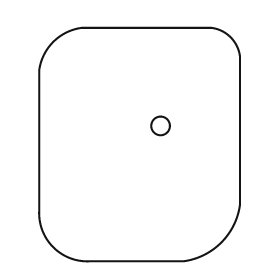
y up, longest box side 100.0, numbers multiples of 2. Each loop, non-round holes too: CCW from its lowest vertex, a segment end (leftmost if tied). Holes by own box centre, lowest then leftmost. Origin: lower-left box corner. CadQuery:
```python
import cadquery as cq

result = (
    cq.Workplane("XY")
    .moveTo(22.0, 0.0)
    .lineTo(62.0, 0.0)
    .threePointArc((78.0, 8.0), (86.0, 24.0))
    .lineTo(86.0, 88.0)
    .threePointArc((82.0, 96.0), (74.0, 100.0))
    .lineTo(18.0, 100.0)
    .threePointArc((6.0, 94.0), (0.0, 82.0))
    .lineTo(0.0, 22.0)
    .threePointArc((6.0, 6.0), (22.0, 0.0))
    .close()
    .moveTo(52.0, 58.0)
    .circle(4.0)
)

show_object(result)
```